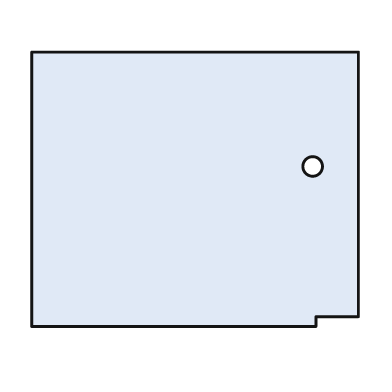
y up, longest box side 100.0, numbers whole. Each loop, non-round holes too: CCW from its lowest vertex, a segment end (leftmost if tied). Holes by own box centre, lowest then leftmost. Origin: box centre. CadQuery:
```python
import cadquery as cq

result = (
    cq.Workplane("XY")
    .moveTo(-50.0, -42.0)
    .lineTo(37.0, -42.0)
    .lineTo(37.0, -39.0)
    .lineTo(50.0, -39.0)
    .lineTo(50.0, 42.0)
    .lineTo(-50.0, 42.0)
    .close()
    .moveTo(36.0, 7.0)
    .circle(3.0)
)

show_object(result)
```